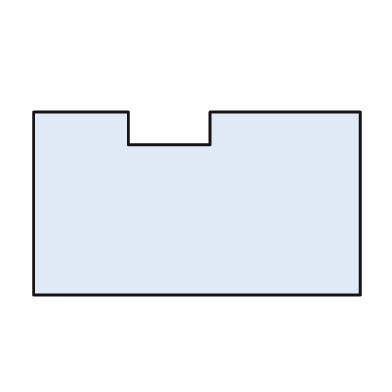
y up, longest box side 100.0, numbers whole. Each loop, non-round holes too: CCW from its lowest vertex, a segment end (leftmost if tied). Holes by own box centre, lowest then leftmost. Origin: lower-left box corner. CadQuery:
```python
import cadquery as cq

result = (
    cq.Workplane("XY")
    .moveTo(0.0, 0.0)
    .lineTo(100.0, 0.0)
    .lineTo(100.0, 56.0)
    .lineTo(54.0, 56.0)
    .lineTo(54.0, 46.0)
    .lineTo(29.0, 46.0)
    .lineTo(29.0, 56.0)
    .lineTo(0.0, 56.0)
    .close()
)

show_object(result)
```